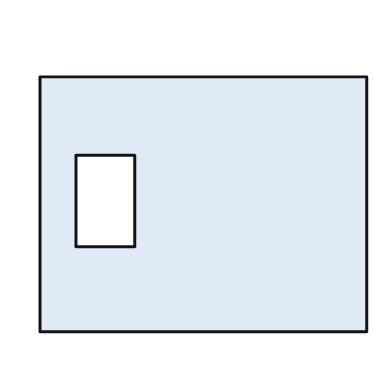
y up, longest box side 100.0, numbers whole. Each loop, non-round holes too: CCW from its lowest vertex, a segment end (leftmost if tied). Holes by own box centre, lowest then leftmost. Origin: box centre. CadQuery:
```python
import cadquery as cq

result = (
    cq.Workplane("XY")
    .moveTo(-50.0, -39.0)
    .lineTo(50.0, -39.0)
    .lineTo(50.0, 39.0)
    .lineTo(-50.0, 39.0)
    .close()
    .moveTo(-39.0, -13.0)
    .lineTo(-21.0, -13.0)
    .lineTo(-21.0, 15.0)
    .lineTo(-39.0, 15.0)
    .close()
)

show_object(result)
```